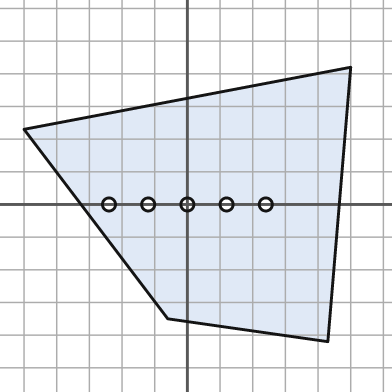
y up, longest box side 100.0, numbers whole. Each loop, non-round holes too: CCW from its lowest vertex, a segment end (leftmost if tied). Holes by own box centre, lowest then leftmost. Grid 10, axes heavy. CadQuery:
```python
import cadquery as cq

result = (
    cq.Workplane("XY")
    .moveTo(43.0, -42.0)
    .lineTo(50.0, 42.0)
    .lineTo(-50.0, 23.0)
    .lineTo(-6.0, -35.0)
    .close()
    .moveTo(-24.0, 0.0)
    .circle(2.0)
    .moveTo(-12.0, 0.0)
    .circle(2.0)
    .moveTo(0.0, 0.0)
    .circle(2.0)
    .moveTo(12.0, 0.0)
    .circle(2.0)
    .moveTo(24.0, 0.0)
    .circle(2.0)
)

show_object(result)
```